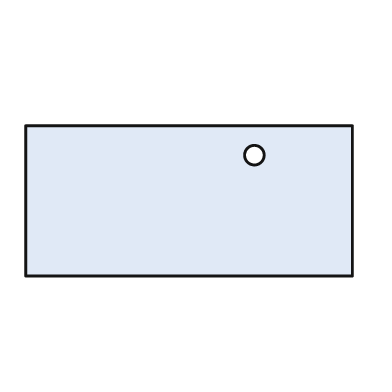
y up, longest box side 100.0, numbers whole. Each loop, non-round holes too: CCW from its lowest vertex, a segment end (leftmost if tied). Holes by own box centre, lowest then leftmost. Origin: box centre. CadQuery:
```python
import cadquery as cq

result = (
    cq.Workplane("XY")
    .moveTo(-50.0, -23.0)
    .lineTo(50.0, -23.0)
    .lineTo(50.0, 23.0)
    .lineTo(-50.0, 23.0)
    .close()
    .moveTo(20.0, 14.0)
    .circle(3.0)
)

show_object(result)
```